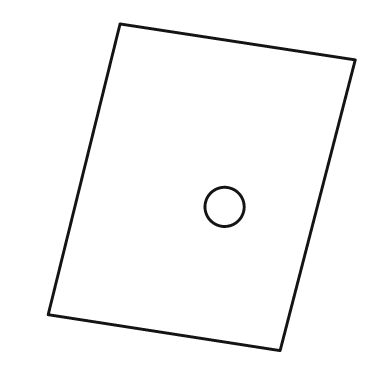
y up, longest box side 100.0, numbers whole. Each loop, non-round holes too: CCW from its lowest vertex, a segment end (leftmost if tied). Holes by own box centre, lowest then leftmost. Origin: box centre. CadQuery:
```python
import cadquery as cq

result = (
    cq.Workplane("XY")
    .moveTo(24.0, -50.0)
    .lineTo(47.0, 39.0)
    .lineTo(-25.0, 50.0)
    .lineTo(-47.0, -39.0)
    .close()
    .moveTo(7.0, -6.0)
    .circle(6.0)
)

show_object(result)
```